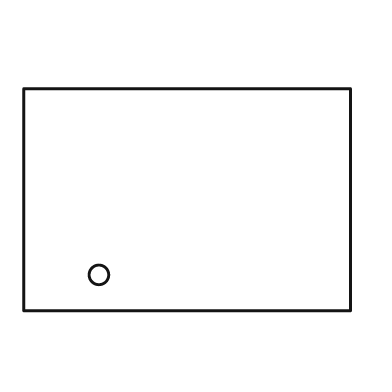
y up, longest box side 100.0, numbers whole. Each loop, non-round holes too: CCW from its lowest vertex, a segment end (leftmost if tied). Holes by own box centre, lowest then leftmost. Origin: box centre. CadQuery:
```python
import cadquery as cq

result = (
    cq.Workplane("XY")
    .moveTo(-50.0, -34.0)
    .lineTo(50.0, -34.0)
    .lineTo(50.0, 34.0)
    .lineTo(-50.0, 34.0)
    .close()
    .moveTo(-27.0, -23.0)
    .circle(3.0)
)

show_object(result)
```